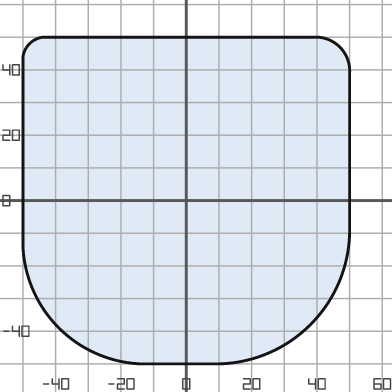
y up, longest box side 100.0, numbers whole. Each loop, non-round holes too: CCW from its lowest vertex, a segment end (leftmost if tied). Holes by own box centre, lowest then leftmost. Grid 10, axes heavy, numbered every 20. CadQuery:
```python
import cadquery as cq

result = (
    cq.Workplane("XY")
    .moveTo(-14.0, -50.0)
    .lineTo(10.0, -50.0)
    .threePointArc((38.0, -38.0), (50.0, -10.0))
    .lineTo(50.0, 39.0)
    .threePointArc((47.0, 47.0), (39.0, 50.0))
    .lineTo(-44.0, 50.0)
    .threePointArc((-48.0, 48.0), (-50.0, 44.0))
    .lineTo(-50.0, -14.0)
    .threePointArc((-39.0, -39.0), (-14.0, -50.0))
    .close()
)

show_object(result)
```